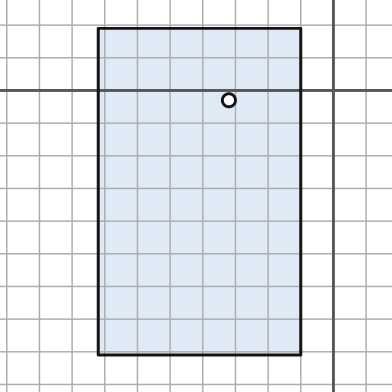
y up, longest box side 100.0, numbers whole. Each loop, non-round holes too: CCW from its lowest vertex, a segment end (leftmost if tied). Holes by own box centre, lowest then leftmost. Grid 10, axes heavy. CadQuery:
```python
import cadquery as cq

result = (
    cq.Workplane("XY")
    .moveTo(-72.0, -81.0)
    .lineTo(-10.0, -81.0)
    .lineTo(-10.0, 19.0)
    .lineTo(-72.0, 19.0)
    .close()
    .moveTo(-32.0, -3.0)
    .circle(2.0)
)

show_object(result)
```